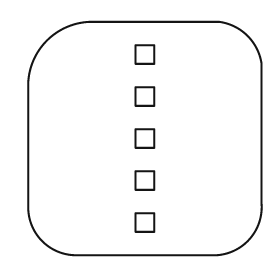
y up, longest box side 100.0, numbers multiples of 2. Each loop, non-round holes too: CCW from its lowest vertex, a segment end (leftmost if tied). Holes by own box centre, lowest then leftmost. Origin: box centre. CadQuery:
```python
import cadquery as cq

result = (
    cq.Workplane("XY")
    .moveTo(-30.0, -50.0)
    .lineTo(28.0, -50.0)
    .threePointArc((44.0, -44.0), (50.0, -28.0))
    .lineTo(50.0, 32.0)
    .threePointArc((44.0, 44.0), (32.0, 50.0))
    .lineTo(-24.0, 50.0)
    .threePointArc((-42.0, 42.0), (-50.0, 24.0))
    .lineTo(-50.0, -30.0)
    .threePointArc((-44.0, -44.0), (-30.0, -50.0))
    .close()
    .moveTo(-4.0, -40.0)
    .lineTo(4.0, -40.0)
    .lineTo(4.0, -32.0)
    .lineTo(-4.0, -32.0)
    .close()
    .moveTo(-4.0, -22.0)
    .lineTo(4.0, -22.0)
    .lineTo(4.0, -14.0)
    .lineTo(-4.0, -14.0)
    .close()
    .moveTo(-4.0, -4.0)
    .lineTo(4.0, -4.0)
    .lineTo(4.0, 4.0)
    .lineTo(-4.0, 4.0)
    .close()
    .moveTo(-4.0, 14.0)
    .lineTo(4.0, 14.0)
    .lineTo(4.0, 22.0)
    .lineTo(-4.0, 22.0)
    .close()
    .moveTo(-4.0, 32.0)
    .lineTo(4.0, 32.0)
    .lineTo(4.0, 40.0)
    .lineTo(-4.0, 40.0)
    .close()
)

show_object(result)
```